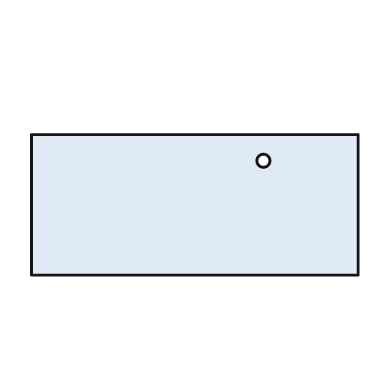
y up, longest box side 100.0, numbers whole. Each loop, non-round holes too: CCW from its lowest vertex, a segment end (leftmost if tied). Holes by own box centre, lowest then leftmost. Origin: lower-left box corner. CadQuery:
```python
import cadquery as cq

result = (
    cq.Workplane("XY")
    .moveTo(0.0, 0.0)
    .lineTo(100.0, 0.0)
    .lineTo(100.0, 43.0)
    .lineTo(0.0, 43.0)
    .close()
    .moveTo(71.0, 35.0)
    .circle(2.0)
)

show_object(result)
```